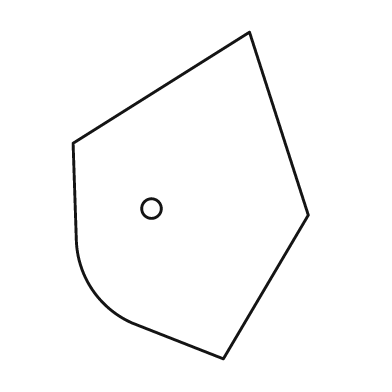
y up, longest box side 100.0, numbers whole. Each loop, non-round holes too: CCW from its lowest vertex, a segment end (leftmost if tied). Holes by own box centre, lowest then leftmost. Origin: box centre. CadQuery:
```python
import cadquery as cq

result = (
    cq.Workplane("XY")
    .moveTo(10.0, -50.0)
    .lineTo(36.0, -6.0)
    .lineTo(18.0, 50.0)
    .lineTo(-36.0, 16.0)
    .lineTo(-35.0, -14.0)
    .threePointArc((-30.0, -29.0), (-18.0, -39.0))
    .close()
    .moveTo(-12.0, -4.0)
    .circle(3.0)
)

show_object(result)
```